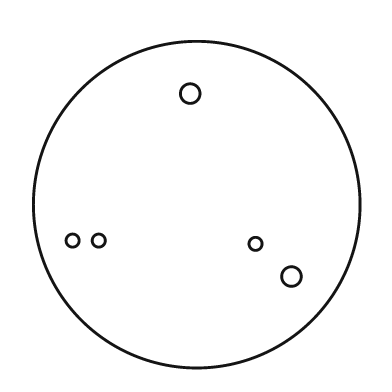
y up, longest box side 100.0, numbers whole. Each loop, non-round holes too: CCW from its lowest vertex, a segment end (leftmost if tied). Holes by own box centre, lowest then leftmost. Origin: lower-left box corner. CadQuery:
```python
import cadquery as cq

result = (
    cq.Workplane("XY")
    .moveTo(50.0, 50.0)
    .circle(50.0)
    .moveTo(79.0, 28.0)
    .circle(3.0)
    .moveTo(68.0, 38.0)
    .circle(2.0)
    .moveTo(12.0, 39.0)
    .circle(2.0)
    .moveTo(20.0, 39.0)
    .circle(2.0)
    .moveTo(48.0, 84.0)
    .circle(3.0)
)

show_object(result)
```